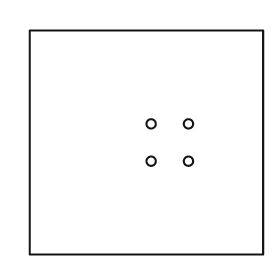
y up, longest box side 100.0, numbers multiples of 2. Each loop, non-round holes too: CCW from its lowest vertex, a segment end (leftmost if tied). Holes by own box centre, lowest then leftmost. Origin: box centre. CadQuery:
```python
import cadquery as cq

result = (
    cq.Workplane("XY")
    .moveTo(-50.0, -48.0)
    .lineTo(50.0, -48.0)
    .lineTo(50.0, 48.0)
    .lineTo(-50.0, 48.0)
    .close()
    .moveTo(2.0, -8.0)
    .circle(2.0)
    .moveTo(18.0, -8.0)
    .circle(2.0)
    .moveTo(2.0, 8.0)
    .circle(2.0)
    .moveTo(18.0, 8.0)
    .circle(2.0)
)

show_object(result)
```